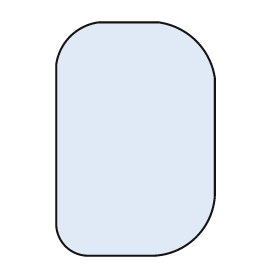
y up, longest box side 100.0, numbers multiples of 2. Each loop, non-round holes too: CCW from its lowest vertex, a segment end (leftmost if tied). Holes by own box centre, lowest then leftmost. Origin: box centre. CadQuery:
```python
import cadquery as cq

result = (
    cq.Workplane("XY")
    .moveTo(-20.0, -50.0)
    .lineTo(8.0, -50.0)
    .threePointArc((26.0, -42.0), (34.0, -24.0))
    .lineTo(34.0, 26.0)
    .threePointArc((26.0, 42.0), (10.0, 50.0))
    .lineTo(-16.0, 50.0)
    .threePointArc((-28.0, 44.0), (-34.0, 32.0))
    .lineTo(-34.0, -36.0)
    .threePointArc((-30.0, -46.0), (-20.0, -50.0))
    .close()
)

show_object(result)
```